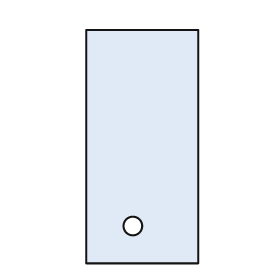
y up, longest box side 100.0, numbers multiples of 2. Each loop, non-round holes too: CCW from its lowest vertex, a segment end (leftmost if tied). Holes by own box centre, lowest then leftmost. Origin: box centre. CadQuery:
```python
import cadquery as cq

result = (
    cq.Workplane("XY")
    .moveTo(-24.0, -50.0)
    .lineTo(24.0, -50.0)
    .lineTo(24.0, 50.0)
    .lineTo(-24.0, 50.0)
    .close()
    .moveTo(-4.0, -34.0)
    .circle(4.0)
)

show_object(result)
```